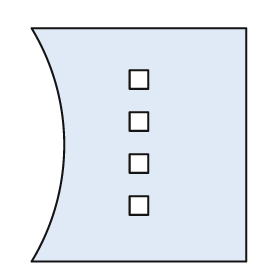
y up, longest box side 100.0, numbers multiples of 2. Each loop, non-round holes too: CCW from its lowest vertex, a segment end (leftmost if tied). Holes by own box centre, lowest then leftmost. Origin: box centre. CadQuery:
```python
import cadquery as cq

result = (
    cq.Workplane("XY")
    .moveTo(-46.0, -50.0)
    .lineTo(46.0, -50.0)
    .lineTo(46.0, 50.0)
    .lineTo(-46.0, 50.0)
    .threePointArc((-32.0, 0.0), (-46.0, -50.0))
    .close()
    .moveTo(-4.0, -30.0)
    .lineTo(4.0, -30.0)
    .lineTo(4.0, -22.0)
    .lineTo(-4.0, -22.0)
    .close()
    .moveTo(-4.0, -12.0)
    .lineTo(4.0, -12.0)
    .lineTo(4.0, -4.0)
    .lineTo(-4.0, -4.0)
    .close()
    .moveTo(-4.0, 6.0)
    .lineTo(4.0, 6.0)
    .lineTo(4.0, 14.0)
    .lineTo(-4.0, 14.0)
    .close()
    .moveTo(-4.0, 24.0)
    .lineTo(4.0, 24.0)
    .lineTo(4.0, 32.0)
    .lineTo(-4.0, 32.0)
    .close()
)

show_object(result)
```